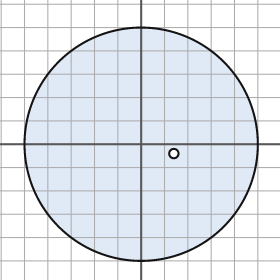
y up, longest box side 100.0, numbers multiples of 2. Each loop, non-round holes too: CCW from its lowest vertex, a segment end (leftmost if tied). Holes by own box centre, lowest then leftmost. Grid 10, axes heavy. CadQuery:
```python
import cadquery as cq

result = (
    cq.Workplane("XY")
    .moveTo(0.0, 0.0)
    .circle(50.0)
    .moveTo(14.0, -4.0)
    .circle(2.0)
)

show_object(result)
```